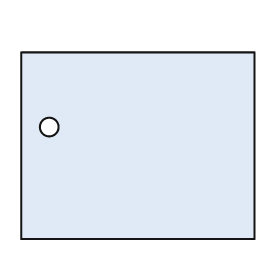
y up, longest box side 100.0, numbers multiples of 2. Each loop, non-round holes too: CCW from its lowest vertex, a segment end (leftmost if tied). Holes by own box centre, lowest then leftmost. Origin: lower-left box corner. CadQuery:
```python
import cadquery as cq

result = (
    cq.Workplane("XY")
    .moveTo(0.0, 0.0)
    .lineTo(100.0, 0.0)
    .lineTo(100.0, 80.0)
    .lineTo(0.0, 80.0)
    .close()
    .moveTo(12.0, 48.0)
    .circle(4.0)
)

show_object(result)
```